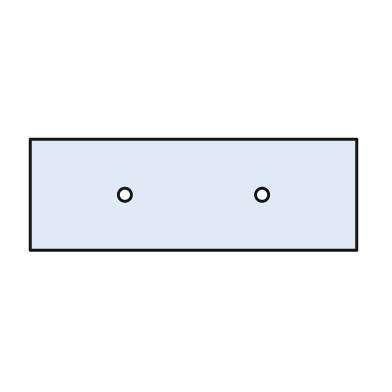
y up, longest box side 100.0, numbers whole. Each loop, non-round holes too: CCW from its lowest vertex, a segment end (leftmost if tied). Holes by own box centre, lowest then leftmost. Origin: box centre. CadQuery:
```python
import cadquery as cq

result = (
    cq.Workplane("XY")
    .moveTo(-50.0, -17.0)
    .lineTo(50.0, -17.0)
    .lineTo(50.0, 17.0)
    .lineTo(-50.0, 17.0)
    .close()
    .moveTo(-21.0, 0.0)
    .circle(2.0)
    .moveTo(21.0, 0.0)
    .circle(2.0)
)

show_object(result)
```